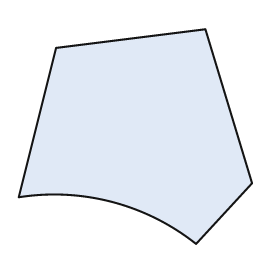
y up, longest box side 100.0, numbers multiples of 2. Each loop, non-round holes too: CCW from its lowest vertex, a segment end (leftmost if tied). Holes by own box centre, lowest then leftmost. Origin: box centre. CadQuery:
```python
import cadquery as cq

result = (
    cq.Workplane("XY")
    .moveTo(26.0, -46.0)
    .lineTo(50.0, -20.0)
    .lineTo(30.0, 46.0)
    .lineTo(-34.0, 38.0)
    .lineTo(-50.0, -26.0)
    .threePointArc((-10.0, -28.0), (26.0, -46.0))
    .close()
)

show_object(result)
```